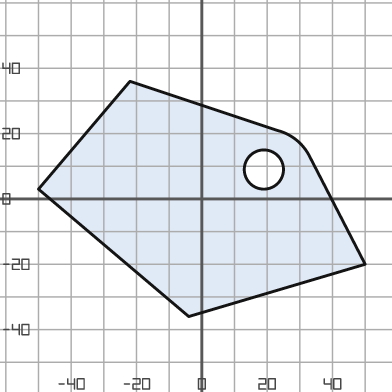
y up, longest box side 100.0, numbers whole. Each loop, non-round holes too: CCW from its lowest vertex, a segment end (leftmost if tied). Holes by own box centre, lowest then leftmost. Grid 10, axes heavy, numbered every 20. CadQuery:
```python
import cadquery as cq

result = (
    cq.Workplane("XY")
    .moveTo(-4.0, -36.0)
    .lineTo(50.0, -20.0)
    .lineTo(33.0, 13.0)
    .threePointArc((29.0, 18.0), (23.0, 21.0))
    .lineTo(-22.0, 36.0)
    .lineTo(-50.0, 3.0)
    .close()
    .moveTo(19.0, 9.0)
    .circle(6.0)
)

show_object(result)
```